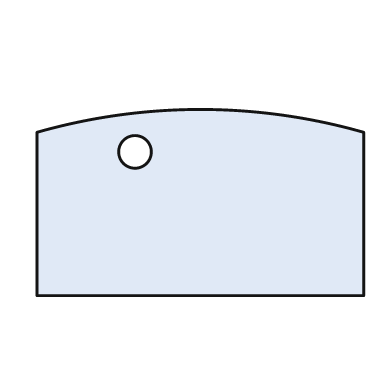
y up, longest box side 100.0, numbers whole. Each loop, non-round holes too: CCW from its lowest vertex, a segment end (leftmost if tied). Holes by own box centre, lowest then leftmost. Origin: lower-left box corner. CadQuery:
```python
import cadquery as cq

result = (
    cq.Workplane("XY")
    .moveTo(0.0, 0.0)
    .lineTo(100.0, 0.0)
    .lineTo(100.0, 50.0)
    .threePointArc((50.0, 57.0), (0.0, 50.0))
    .close()
    .moveTo(30.0, 44.0)
    .circle(5.0)
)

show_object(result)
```